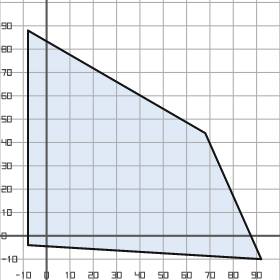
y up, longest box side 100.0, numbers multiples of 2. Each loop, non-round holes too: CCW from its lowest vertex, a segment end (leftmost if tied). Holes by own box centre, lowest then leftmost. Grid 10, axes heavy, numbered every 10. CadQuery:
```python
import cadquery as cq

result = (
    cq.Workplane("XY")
    .moveTo(92.0, -10.0)
    .lineTo(68.0, 44.0)
    .lineTo(-8.0, 88.0)
    .lineTo(-8.0, -4.0)
    .close()
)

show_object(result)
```